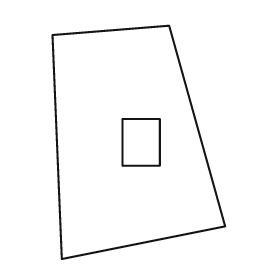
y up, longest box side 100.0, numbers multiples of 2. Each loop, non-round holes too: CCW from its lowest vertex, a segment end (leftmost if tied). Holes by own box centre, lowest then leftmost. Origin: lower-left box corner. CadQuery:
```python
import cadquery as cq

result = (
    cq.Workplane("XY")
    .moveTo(4.0, 0.0)
    .lineTo(74.0, 14.0)
    .lineTo(50.0, 100.0)
    .lineTo(0.0, 96.0)
    .close()
    .moveTo(30.0, 40.0)
    .lineTo(46.0, 40.0)
    .lineTo(46.0, 60.0)
    .lineTo(30.0, 60.0)
    .close()
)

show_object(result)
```